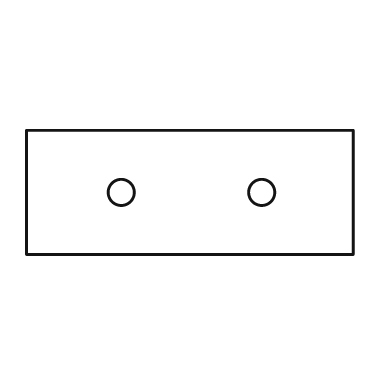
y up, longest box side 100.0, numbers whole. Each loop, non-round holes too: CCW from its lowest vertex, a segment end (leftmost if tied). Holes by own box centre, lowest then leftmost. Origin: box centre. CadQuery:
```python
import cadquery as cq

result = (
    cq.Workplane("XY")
    .moveTo(-50.0, -19.0)
    .lineTo(50.0, -19.0)
    .lineTo(50.0, 19.0)
    .lineTo(-50.0, 19.0)
    .close()
    .moveTo(-21.0, 0.0)
    .circle(4.0)
    .moveTo(22.0, 0.0)
    .circle(4.0)
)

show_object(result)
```